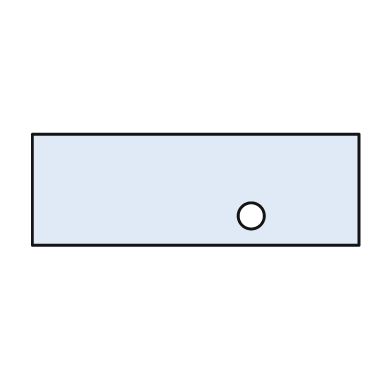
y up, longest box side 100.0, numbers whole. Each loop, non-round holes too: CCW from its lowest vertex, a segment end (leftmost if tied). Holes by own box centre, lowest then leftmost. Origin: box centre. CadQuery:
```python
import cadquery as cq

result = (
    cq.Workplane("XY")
    .moveTo(-50.0, -17.0)
    .lineTo(50.0, -17.0)
    .lineTo(50.0, 17.0)
    .lineTo(-50.0, 17.0)
    .close()
    .moveTo(17.0, -8.0)
    .circle(4.0)
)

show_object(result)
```